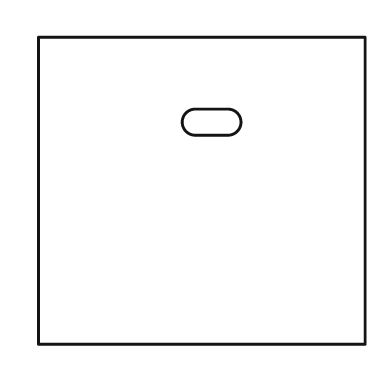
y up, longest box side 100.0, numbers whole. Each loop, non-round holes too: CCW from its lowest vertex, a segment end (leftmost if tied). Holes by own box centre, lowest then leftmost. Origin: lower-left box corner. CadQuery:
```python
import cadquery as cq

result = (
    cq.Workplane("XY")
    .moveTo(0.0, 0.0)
    .lineTo(100.0, 0.0)
    .lineTo(100.0, 94.0)
    .lineTo(0.0, 94.0)
    .close()
    .moveTo(48.0, 64.0)
    .lineTo(58.0, 64.0)
    .threePointArc((62.0, 68.0), (58.0, 72.0))
    .lineTo(48.0, 72.0)
    .threePointArc((44.0, 68.0), (48.0, 64.0))
    .close()
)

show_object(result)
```